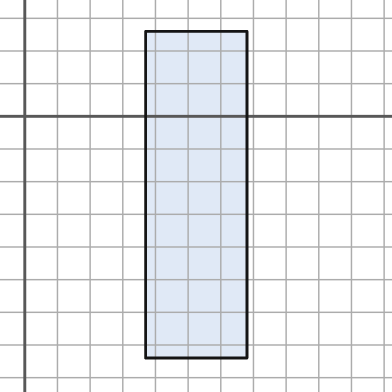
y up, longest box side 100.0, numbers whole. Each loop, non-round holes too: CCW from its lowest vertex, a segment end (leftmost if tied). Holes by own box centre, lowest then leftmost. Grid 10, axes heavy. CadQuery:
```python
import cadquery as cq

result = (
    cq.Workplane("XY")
    .moveTo(37.0, -74.0)
    .lineTo(68.0, -74.0)
    .lineTo(68.0, 26.0)
    .lineTo(37.0, 26.0)
    .close()
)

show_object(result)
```